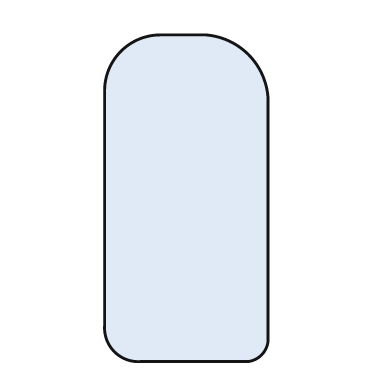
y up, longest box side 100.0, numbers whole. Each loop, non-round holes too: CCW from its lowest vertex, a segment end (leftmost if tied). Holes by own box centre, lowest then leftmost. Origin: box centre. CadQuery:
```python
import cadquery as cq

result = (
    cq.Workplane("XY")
    .moveTo(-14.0, -50.0)
    .lineTo(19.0, -50.0)
    .threePointArc((23.0, -48.0), (25.0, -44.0))
    .lineTo(25.0, 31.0)
    .threePointArc((19.0, 44.0), (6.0, 50.0))
    .lineTo(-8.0, 50.0)
    .threePointArc((-20.0, 45.0), (-25.0, 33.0))
    .lineTo(-25.0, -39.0)
    .threePointArc((-22.0, -47.0), (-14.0, -50.0))
    .close()
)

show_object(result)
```